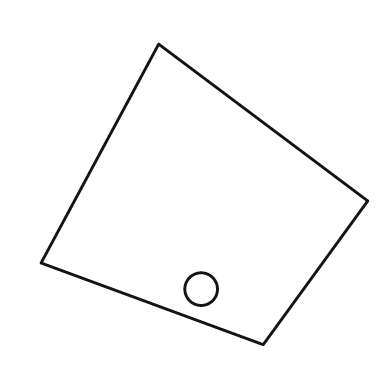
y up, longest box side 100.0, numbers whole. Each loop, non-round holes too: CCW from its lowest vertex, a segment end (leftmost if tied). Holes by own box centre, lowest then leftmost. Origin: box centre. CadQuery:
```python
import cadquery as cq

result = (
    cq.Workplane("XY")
    .moveTo(18.0, -46.0)
    .lineTo(50.0, -2.0)
    .lineTo(-14.0, 46.0)
    .lineTo(-50.0, -21.0)
    .close()
    .moveTo(-1.0, -29.0)
    .circle(5.0)
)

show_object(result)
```